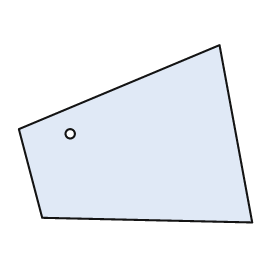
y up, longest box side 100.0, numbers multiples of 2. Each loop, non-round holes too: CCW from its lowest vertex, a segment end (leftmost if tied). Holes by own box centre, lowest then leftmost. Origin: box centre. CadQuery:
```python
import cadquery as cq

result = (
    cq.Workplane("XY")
    .moveTo(50.0, -38.0)
    .lineTo(36.0, 38.0)
    .lineTo(-50.0, 2.0)
    .lineTo(-40.0, -36.0)
    .close()
    .moveTo(-28.0, 0.0)
    .circle(2.0)
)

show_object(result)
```